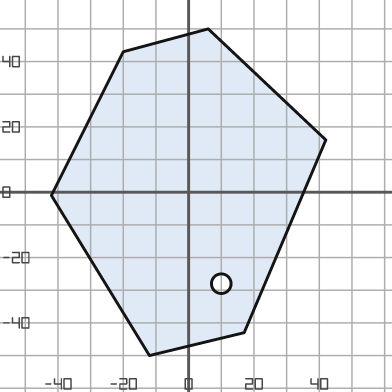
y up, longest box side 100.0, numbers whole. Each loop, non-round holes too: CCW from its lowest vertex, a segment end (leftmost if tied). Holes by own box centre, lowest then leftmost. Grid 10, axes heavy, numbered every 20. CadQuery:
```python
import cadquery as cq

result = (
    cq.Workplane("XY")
    .moveTo(-12.0, -50.0)
    .lineTo(17.0, -43.0)
    .lineTo(42.0, 16.0)
    .lineTo(6.0, 50.0)
    .lineTo(-20.0, 43.0)
    .lineTo(-42.0, -1.0)
    .close()
    .moveTo(10.0, -28.0)
    .circle(3.0)
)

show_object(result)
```